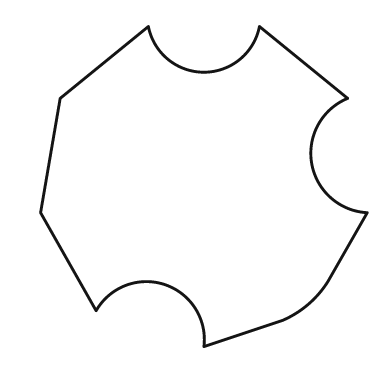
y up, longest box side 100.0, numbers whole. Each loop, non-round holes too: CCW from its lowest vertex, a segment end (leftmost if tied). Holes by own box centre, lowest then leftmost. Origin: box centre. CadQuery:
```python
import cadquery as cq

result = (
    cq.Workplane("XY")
    .moveTo(0.0, -49.0)
    .lineTo(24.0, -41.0)
    .threePointArc((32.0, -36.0), (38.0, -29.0))
    .lineTo(50.0, -8.0)
    .threePointArc((33.0, 7.0), (44.0, 27.0))
    .lineTo(17.0, 49.0)
    .threePointArc((0.0, 35.0), (-17.0, 49.0))
    .lineTo(-44.0, 27.0)
    .lineTo(-50.0, -8.0)
    .lineTo(-33.0, -38.0)
    .threePointArc((-12.0, -30.0), (0.0, -49.0))
    .close()
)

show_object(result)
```